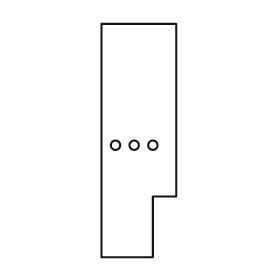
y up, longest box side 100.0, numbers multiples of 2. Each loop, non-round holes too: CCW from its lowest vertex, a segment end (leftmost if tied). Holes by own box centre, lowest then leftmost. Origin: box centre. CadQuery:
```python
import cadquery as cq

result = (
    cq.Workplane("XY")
    .moveTo(-16.0, -50.0)
    .lineTo(6.0, -50.0)
    .lineTo(6.0, -24.0)
    .lineTo(16.0, -24.0)
    .lineTo(16.0, 50.0)
    .lineTo(-16.0, 50.0)
    .close()
    .moveTo(-10.0, -2.0)
    .circle(2.0)
    .moveTo(-2.0, -2.0)
    .circle(2.0)
    .moveTo(6.0, -2.0)
    .circle(2.0)
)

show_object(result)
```